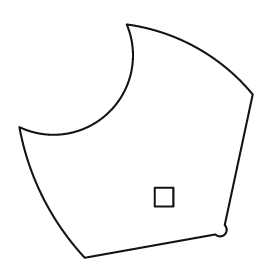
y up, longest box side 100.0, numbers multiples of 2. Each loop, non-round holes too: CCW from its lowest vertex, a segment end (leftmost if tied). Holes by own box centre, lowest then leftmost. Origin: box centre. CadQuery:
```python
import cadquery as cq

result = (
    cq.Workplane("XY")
    .moveTo(-22.0, -50.0)
    .lineTo(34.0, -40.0)
    .threePointArc((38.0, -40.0), (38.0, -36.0))
    .lineTo(50.0, 20.0)
    .threePointArc((26.0, 40.0), (-4.0, 50.0))
    .threePointArc((-12.0, 12.0), (-50.0, 6.0))
    .threePointArc((-40.0, -24.0), (-22.0, -50.0))
    .close()
    .moveTo(8.0, -28.0)
    .lineTo(16.0, -28.0)
    .lineTo(16.0, -20.0)
    .lineTo(8.0, -20.0)
    .close()
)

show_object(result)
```